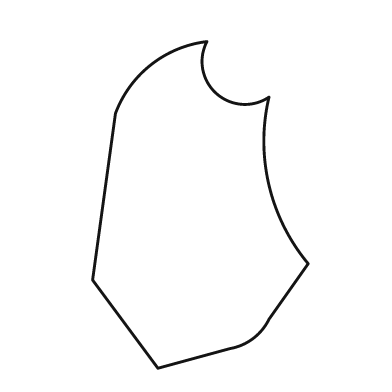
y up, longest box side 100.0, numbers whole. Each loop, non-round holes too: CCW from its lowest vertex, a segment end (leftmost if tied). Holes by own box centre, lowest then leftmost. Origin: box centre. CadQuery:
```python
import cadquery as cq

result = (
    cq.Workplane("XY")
    .moveTo(-13.0, -50.0)
    .lineTo(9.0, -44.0)
    .threePointArc((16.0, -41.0), (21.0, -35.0))
    .lineTo(33.0, -18.0)
    .threePointArc((21.0, 6.0), (21.0, 33.0))
    .threePointArc((5.0, 34.0), (2.0, 50.0))
    .threePointArc((-15.0, 43.0), (-26.0, 28.0))
    .lineTo(-33.0, -23.0)
    .close()
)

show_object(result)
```